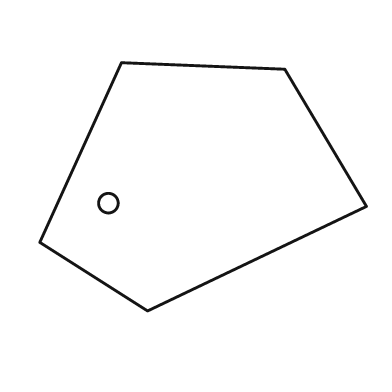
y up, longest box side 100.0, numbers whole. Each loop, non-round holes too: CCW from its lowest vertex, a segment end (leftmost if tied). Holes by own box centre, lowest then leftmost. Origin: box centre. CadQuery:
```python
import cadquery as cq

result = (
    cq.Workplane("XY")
    .moveTo(-17.0, -38.0)
    .lineTo(50.0, -6.0)
    .lineTo(25.0, 36.0)
    .lineTo(-25.0, 38.0)
    .lineTo(-50.0, -17.0)
    .close()
    .moveTo(-29.0, -5.0)
    .circle(3.0)
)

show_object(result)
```